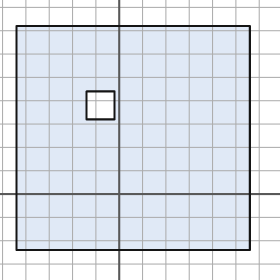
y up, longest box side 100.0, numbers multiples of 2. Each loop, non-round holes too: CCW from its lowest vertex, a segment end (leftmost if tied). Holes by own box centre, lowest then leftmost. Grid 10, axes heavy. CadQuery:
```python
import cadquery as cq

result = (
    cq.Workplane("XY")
    .moveTo(-44.0, -24.0)
    .lineTo(56.0, -24.0)
    .lineTo(56.0, 72.0)
    .lineTo(-44.0, 72.0)
    .close()
    .moveTo(-14.0, 32.0)
    .lineTo(-2.0, 32.0)
    .lineTo(-2.0, 44.0)
    .lineTo(-14.0, 44.0)
    .close()
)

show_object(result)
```